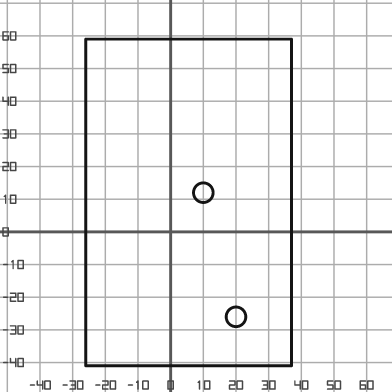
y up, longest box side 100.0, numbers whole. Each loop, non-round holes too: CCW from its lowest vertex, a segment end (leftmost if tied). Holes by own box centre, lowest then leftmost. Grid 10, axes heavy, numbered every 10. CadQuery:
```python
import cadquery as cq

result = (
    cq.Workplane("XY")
    .moveTo(-26.0, -41.0)
    .lineTo(37.0, -41.0)
    .lineTo(37.0, 59.0)
    .lineTo(-26.0, 59.0)
    .close()
    .moveTo(20.0, -26.0)
    .circle(3.0)
    .moveTo(10.0, 12.0)
    .circle(3.0)
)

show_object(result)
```